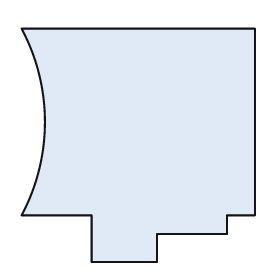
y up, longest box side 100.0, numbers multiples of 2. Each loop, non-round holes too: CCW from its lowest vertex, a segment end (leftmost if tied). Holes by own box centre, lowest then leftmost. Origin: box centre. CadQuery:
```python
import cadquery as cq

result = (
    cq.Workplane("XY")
    .moveTo(-20.0, -50.0)
    .lineTo(8.0, -50.0)
    .lineTo(8.0, -38.0)
    .lineTo(38.0, -38.0)
    .lineTo(38.0, -30.0)
    .lineTo(50.0, -30.0)
    .lineTo(50.0, 50.0)
    .lineTo(-50.0, 50.0)
    .threePointArc((-40.0, 10.0), (-50.0, -30.0))
    .lineTo(-20.0, -30.0)
    .close()
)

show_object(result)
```